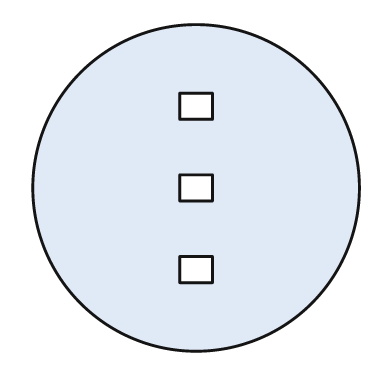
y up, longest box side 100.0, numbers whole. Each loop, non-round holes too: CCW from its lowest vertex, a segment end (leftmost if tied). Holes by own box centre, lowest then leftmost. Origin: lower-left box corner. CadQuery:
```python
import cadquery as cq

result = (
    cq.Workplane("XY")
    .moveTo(50.0, 50.0)
    .circle(50.0)
    .moveTo(45.0, 21.0)
    .lineTo(55.0, 21.0)
    .lineTo(55.0, 29.0)
    .lineTo(45.0, 29.0)
    .close()
    .moveTo(45.0, 46.0)
    .lineTo(55.0, 46.0)
    .lineTo(55.0, 54.0)
    .lineTo(45.0, 54.0)
    .close()
    .moveTo(45.0, 71.0)
    .lineTo(55.0, 71.0)
    .lineTo(55.0, 79.0)
    .lineTo(45.0, 79.0)
    .close()
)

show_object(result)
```